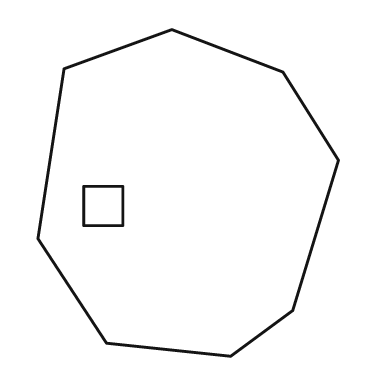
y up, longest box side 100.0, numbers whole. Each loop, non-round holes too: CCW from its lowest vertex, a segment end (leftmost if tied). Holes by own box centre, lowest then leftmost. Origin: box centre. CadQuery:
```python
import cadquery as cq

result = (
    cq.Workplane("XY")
    .moveTo(13.0, -50.0)
    .lineTo(32.0, -36.0)
    .lineTo(46.0, 10.0)
    .lineTo(29.0, 37.0)
    .lineTo(-5.0, 50.0)
    .lineTo(-38.0, 38.0)
    .lineTo(-46.0, -14.0)
    .lineTo(-25.0, -46.0)
    .close()
    .moveTo(-32.0, -10.0)
    .lineTo(-20.0, -10.0)
    .lineTo(-20.0, 2.0)
    .lineTo(-32.0, 2.0)
    .close()
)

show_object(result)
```